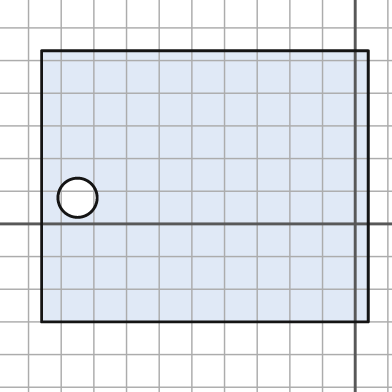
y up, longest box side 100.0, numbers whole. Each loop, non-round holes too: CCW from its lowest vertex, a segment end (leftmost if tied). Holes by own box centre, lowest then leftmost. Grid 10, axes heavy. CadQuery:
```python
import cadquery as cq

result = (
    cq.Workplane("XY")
    .moveTo(-96.0, -30.0)
    .lineTo(4.0, -30.0)
    .lineTo(4.0, 53.0)
    .lineTo(-96.0, 53.0)
    .close()
    .moveTo(-85.0, 8.0)
    .circle(6.0)
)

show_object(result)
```